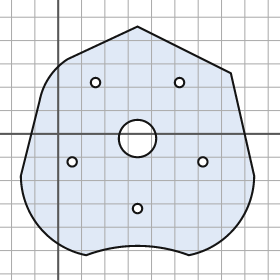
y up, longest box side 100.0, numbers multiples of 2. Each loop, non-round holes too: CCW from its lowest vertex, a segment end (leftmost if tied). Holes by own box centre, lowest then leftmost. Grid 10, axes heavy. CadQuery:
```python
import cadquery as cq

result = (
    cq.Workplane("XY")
    .moveTo(12.0, -52.0)
    .threePointArc((34.0, -48.0), (56.0, -52.0))
    .threePointArc((76.0, -40.0), (84.0, -18.0))
    .lineTo(74.0, 26.0)
    .lineTo(34.0, 46.0)
    .lineTo(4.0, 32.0)
    .threePointArc((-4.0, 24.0), (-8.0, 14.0))
    .lineTo(-16.0, -18.0)
    .threePointArc((-8.0, -40.0), (12.0, -52.0))
    .close()
    .moveTo(34.0, -32.0)
    .circle(2.0)
    .moveTo(6.0, -12.0)
    .circle(2.0)
    .moveTo(62.0, -12.0)
    .circle(2.0)
    .moveTo(34.0, -2.0)
    .circle(8.0)
    .moveTo(16.0, 22.0)
    .circle(2.0)
    .moveTo(52.0, 22.0)
    .circle(2.0)
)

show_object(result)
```